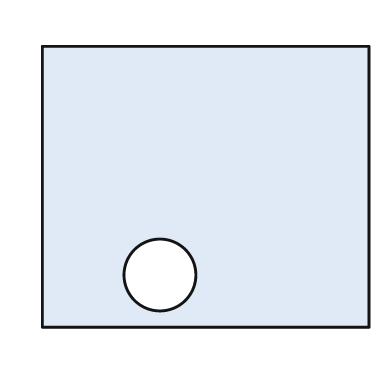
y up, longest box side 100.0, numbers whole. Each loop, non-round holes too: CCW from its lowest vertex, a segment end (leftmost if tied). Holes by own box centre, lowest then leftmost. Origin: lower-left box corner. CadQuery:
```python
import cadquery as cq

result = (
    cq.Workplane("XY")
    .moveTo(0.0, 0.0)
    .lineTo(100.0, 0.0)
    .lineTo(100.0, 86.0)
    .lineTo(0.0, 86.0)
    .close()
    .moveTo(36.0, 16.0)
    .circle(11.0)
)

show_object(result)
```